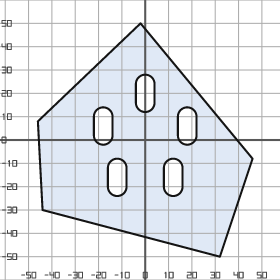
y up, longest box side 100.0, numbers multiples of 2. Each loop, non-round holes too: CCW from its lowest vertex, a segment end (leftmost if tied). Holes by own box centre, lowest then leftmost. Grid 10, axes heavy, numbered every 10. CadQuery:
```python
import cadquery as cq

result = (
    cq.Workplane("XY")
    .moveTo(32.0, -50.0)
    .lineTo(46.0, -8.0)
    .lineTo(-2.0, 50.0)
    .lineTo(-46.0, 8.0)
    .lineTo(-44.0, -30.0)
    .close()
    .moveTo(-16.0, -20.0)
    .threePointArc((-12.0, -24.0), (-8.0, -20.0))
    .lineTo(-8.0, -12.0)
    .threePointArc((-12.0, -8.0), (-16.0, -12.0))
    .close()
    .moveTo(8.0, -20.0)
    .threePointArc((12.0, -24.0), (16.0, -20.0))
    .lineTo(16.0, -12.0)
    .threePointArc((12.0, -8.0), (8.0, -12.0))
    .close()
    .moveTo(-22.0, 2.0)
    .threePointArc((-18.0, -2.0), (-14.0, 2.0))
    .lineTo(-14.0, 10.0)
    .threePointArc((-18.0, 14.0), (-22.0, 10.0))
    .close()
    .moveTo(14.0, 2.0)
    .threePointArc((18.0, -2.0), (22.0, 2.0))
    .lineTo(22.0, 10.0)
    .threePointArc((18.0, 14.0), (14.0, 10.0))
    .close()
    .moveTo(-4.0, 16.0)
    .threePointArc((0.0, 12.0), (4.0, 16.0))
    .lineTo(4.0, 24.0)
    .threePointArc((0.0, 28.0), (-4.0, 24.0))
    .close()
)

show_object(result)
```